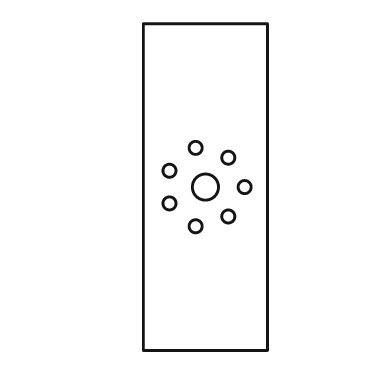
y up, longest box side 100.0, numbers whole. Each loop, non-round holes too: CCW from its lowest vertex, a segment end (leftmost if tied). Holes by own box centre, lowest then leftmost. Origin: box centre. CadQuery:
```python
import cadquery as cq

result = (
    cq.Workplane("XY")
    .moveTo(-19.0, -50.0)
    .lineTo(19.0, -50.0)
    .lineTo(19.0, 50.0)
    .lineTo(-19.0, 50.0)
    .close()
    .moveTo(-3.0, -12.0)
    .circle(2.0)
    .moveTo(7.0, -9.0)
    .circle(2.0)
    .moveTo(-11.0, -5.0)
    .circle(2.0)
    .moveTo(0.0, 0.0)
    .circle(4.0)
    .moveTo(12.0, 0.0)
    .circle(2.0)
    .moveTo(-11.0, 5.0)
    .circle(2.0)
    .moveTo(7.0, 9.0)
    .circle(2.0)
    .moveTo(-3.0, 12.0)
    .circle(2.0)
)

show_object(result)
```